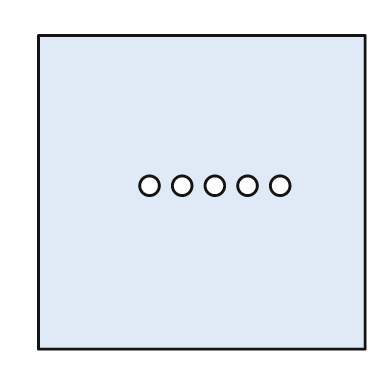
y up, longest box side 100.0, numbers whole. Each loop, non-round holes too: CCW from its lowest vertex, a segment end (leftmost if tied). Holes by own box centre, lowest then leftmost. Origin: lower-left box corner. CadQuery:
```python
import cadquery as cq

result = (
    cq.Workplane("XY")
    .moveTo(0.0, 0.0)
    .lineTo(100.0, 0.0)
    .lineTo(100.0, 96.0)
    .lineTo(0.0, 96.0)
    .close()
    .moveTo(34.0, 50.0)
    .circle(3.0)
    .moveTo(44.0, 50.0)
    .circle(3.0)
    .moveTo(54.0, 50.0)
    .circle(3.0)
    .moveTo(64.0, 50.0)
    .circle(3.0)
    .moveTo(74.0, 50.0)
    .circle(3.0)
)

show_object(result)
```